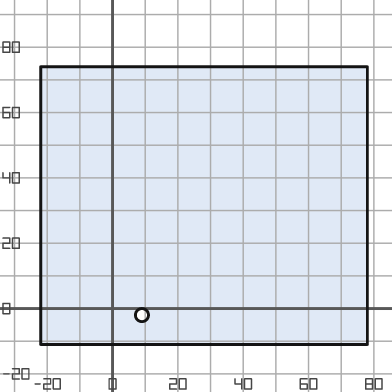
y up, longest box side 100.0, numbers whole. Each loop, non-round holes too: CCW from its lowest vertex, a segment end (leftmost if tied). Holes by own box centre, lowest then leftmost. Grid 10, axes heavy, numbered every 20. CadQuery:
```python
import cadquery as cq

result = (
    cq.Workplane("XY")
    .moveTo(-22.0, -11.0)
    .lineTo(78.0, -11.0)
    .lineTo(78.0, 74.0)
    .lineTo(-22.0, 74.0)
    .close()
    .moveTo(9.0, -2.0)
    .circle(2.0)
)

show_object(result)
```